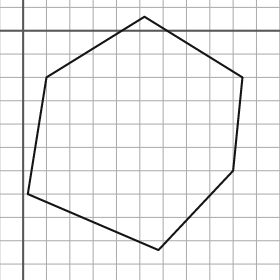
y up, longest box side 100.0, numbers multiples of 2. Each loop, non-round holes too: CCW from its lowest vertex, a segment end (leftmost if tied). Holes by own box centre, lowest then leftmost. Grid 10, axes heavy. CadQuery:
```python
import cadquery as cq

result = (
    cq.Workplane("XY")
    .moveTo(58.0, -94.0)
    .lineTo(90.0, -60.0)
    .lineTo(94.0, -20.0)
    .lineTo(52.0, 6.0)
    .lineTo(10.0, -20.0)
    .lineTo(2.0, -70.0)
    .close()
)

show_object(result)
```